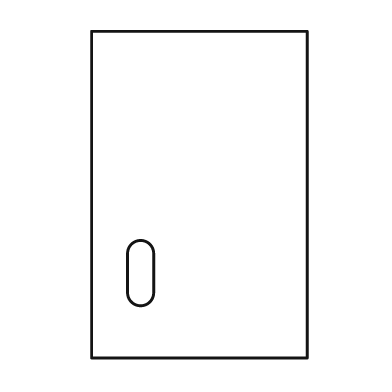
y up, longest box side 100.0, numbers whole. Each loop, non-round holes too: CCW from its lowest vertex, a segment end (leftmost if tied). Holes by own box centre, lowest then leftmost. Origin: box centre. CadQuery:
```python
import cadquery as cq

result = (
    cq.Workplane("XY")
    .moveTo(-33.0, -50.0)
    .lineTo(33.0, -50.0)
    .lineTo(33.0, 50.0)
    .lineTo(-33.0, 50.0)
    .close()
    .moveTo(-22.0, -30.0)
    .threePointArc((-18.0, -34.0), (-14.0, -30.0))
    .lineTo(-14.0, -18.0)
    .threePointArc((-18.0, -14.0), (-22.0, -18.0))
    .close()
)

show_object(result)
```